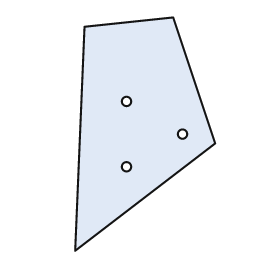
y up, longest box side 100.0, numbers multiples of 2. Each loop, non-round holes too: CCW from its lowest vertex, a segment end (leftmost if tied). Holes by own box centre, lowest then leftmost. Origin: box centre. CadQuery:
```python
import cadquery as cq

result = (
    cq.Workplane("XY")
    .moveTo(-30.0, -50.0)
    .lineTo(30.0, -4.0)
    .lineTo(12.0, 50.0)
    .lineTo(-26.0, 46.0)
    .close()
    .moveTo(-8.0, -14.0)
    .circle(2.0)
    .moveTo(16.0, 0.0)
    .circle(2.0)
    .moveTo(-8.0, 14.0)
    .circle(2.0)
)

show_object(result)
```